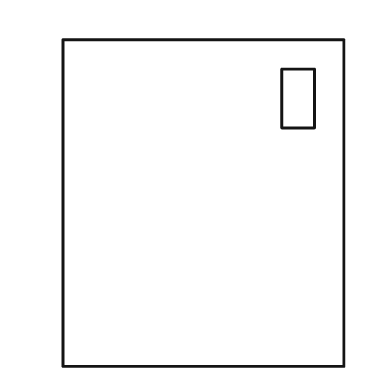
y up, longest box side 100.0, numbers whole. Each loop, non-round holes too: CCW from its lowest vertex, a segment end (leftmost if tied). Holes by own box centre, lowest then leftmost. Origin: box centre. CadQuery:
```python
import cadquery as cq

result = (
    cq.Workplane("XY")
    .moveTo(-43.0, -50.0)
    .lineTo(43.0, -50.0)
    .lineTo(43.0, 50.0)
    .lineTo(-43.0, 50.0)
    .close()
    .moveTo(24.0, 23.0)
    .lineTo(34.0, 23.0)
    .lineTo(34.0, 41.0)
    .lineTo(24.0, 41.0)
    .close()
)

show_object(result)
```